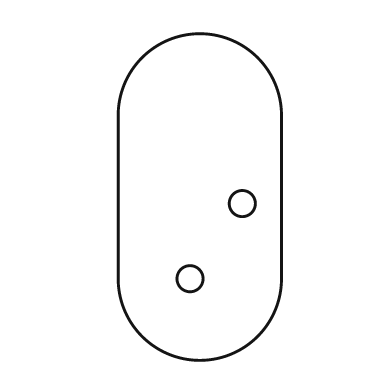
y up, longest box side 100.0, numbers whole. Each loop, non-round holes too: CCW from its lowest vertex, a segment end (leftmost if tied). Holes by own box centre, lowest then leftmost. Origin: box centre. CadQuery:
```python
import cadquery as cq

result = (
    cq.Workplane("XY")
    .moveTo(-25.0, -25.0)
    .threePointArc((0.0, -50.0), (25.0, -25.0))
    .lineTo(25.0, 25.0)
    .threePointArc((0.0, 50.0), (-25.0, 25.0))
    .close()
    .moveTo(-3.0, -25.0)
    .circle(4.0)
    .moveTo(13.0, -2.0)
    .circle(4.0)
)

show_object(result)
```